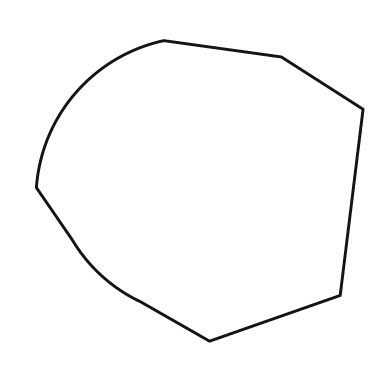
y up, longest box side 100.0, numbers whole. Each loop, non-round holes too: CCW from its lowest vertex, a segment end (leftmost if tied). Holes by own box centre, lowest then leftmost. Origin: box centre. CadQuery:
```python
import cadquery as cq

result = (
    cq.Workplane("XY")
    .moveTo(3.0, -46.0)
    .lineTo(43.0, -32.0)
    .lineTo(50.0, 25.0)
    .lineTo(25.0, 41.0)
    .lineTo(-11.0, 46.0)
    .threePointArc((-38.0, 30.0), (-50.0, 1.0))
    .lineTo(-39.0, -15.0)
    .threePointArc((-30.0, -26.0), (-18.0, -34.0))
    .close()
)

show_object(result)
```